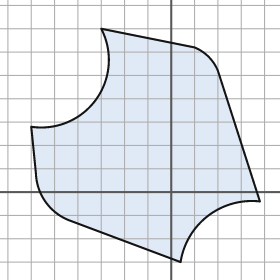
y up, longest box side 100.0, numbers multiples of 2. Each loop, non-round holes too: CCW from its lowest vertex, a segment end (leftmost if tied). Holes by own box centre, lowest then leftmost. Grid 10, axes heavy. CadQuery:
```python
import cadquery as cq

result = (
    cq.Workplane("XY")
    .moveTo(4.0, -30.0)
    .threePointArc((16.0, -10.0), (38.0, -4.0))
    .lineTo(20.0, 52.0)
    .threePointArc((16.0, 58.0), (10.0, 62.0))
    .lineTo(-30.0, 70.0)
    .threePointArc((-32.0, 40.0), (-60.0, 28.0))
    .lineTo(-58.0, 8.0)
    .threePointArc((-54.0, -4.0), (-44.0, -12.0))
    .close()
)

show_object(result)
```